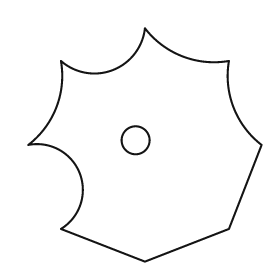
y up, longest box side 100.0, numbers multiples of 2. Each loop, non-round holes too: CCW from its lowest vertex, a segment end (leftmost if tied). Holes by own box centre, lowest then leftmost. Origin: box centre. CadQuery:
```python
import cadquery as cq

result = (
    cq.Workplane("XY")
    .moveTo(0.0, -50.0)
    .lineTo(36.0, -36.0)
    .lineTo(50.0, 0.0)
    .threePointArc((38.0, 16.0), (36.0, 36.0))
    .threePointArc((16.0, 38.0), (0.0, 50.0))
    .threePointArc((-14.0, 32.0), (-36.0, 36.0))
    .threePointArc((-38.0, 16.0), (-50.0, 0.0))
    .threePointArc((-28.0, -12.0), (-36.0, -36.0))
    .close()
    .moveTo(-4.0, 2.0)
    .circle(6.0)
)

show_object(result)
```